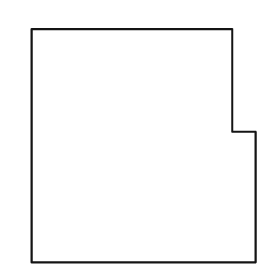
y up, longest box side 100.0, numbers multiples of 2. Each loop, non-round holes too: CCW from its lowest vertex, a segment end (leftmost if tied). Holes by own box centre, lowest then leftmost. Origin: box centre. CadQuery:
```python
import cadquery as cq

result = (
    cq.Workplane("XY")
    .moveTo(-48.0, -50.0)
    .lineTo(48.0, -50.0)
    .lineTo(48.0, 6.0)
    .lineTo(38.0, 6.0)
    .lineTo(38.0, 50.0)
    .lineTo(-48.0, 50.0)
    .close()
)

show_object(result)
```